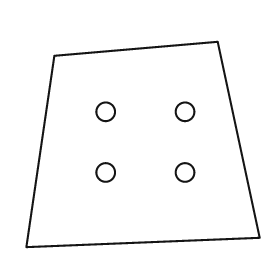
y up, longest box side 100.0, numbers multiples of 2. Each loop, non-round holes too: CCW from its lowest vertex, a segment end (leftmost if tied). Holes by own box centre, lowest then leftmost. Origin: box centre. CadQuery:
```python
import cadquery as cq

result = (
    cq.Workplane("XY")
    .moveTo(-50.0, -44.0)
    .lineTo(50.0, -40.0)
    .lineTo(32.0, 44.0)
    .lineTo(-38.0, 38.0)
    .close()
    .moveTo(-16.0, -12.0)
    .circle(4.0)
    .moveTo(18.0, -12.0)
    .circle(4.0)
    .moveTo(-16.0, 14.0)
    .circle(4.0)
    .moveTo(18.0, 14.0)
    .circle(4.0)
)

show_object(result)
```